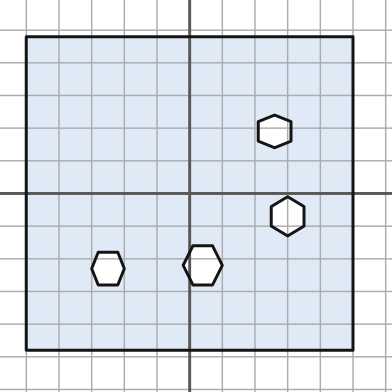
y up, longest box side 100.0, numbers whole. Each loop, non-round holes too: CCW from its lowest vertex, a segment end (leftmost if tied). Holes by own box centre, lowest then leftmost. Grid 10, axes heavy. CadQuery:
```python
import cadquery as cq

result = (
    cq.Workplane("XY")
    .moveTo(-50.0, -48.0)
    .lineTo(50.0, -48.0)
    .lineTo(50.0, 48.0)
    .lineTo(-50.0, 48.0)
    .close()
    .moveTo(-28.0, -28.0)
    .lineTo(-22.0, -28.0)
    .lineTo(-20.0, -23.0)
    .lineTo(-22.0, -18.0)
    .lineTo(-28.0, -18.0)
    .lineTo(-30.0, -23.0)
    .close()
    .moveTo(1.0, -28.0)
    .lineTo(7.0, -28.0)
    .lineTo(10.0, -22.0)
    .lineTo(7.0, -16.0)
    .lineTo(1.0, -16.0)
    .lineTo(-2.0, -22.0)
    .close()
    .moveTo(30.0, -13.0)
    .lineTo(35.0, -10.0)
    .lineTo(35.0, -4.0)
    .lineTo(30.0, -1.0)
    .lineTo(25.0, -4.0)
    .lineTo(25.0, -10.0)
    .close()
    .moveTo(26.0, 14.0)
    .lineTo(31.0, 16.0)
    .lineTo(31.0, 22.0)
    .lineTo(26.0, 24.0)
    .lineTo(21.0, 22.0)
    .lineTo(21.0, 16.0)
    .close()
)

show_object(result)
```